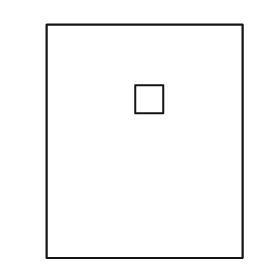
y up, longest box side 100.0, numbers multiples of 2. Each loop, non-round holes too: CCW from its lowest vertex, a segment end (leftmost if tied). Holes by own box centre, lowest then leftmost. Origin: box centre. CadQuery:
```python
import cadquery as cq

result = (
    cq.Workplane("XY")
    .moveTo(-42.0, -50.0)
    .lineTo(42.0, -50.0)
    .lineTo(42.0, 50.0)
    .lineTo(-42.0, 50.0)
    .close()
    .moveTo(-4.0, 12.0)
    .lineTo(8.0, 12.0)
    .lineTo(8.0, 24.0)
    .lineTo(-4.0, 24.0)
    .close()
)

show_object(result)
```